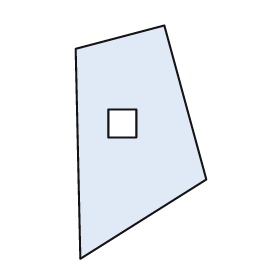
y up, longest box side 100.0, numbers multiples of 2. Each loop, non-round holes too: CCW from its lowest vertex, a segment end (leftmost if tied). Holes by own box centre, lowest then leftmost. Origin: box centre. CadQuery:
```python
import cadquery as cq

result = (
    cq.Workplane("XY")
    .moveTo(-26.0, -50.0)
    .lineTo(28.0, -16.0)
    .lineTo(10.0, 50.0)
    .lineTo(-28.0, 40.0)
    .close()
    .moveTo(-14.0, 2.0)
    .lineTo(-2.0, 2.0)
    .lineTo(-2.0, 14.0)
    .lineTo(-14.0, 14.0)
    .close()
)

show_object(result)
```